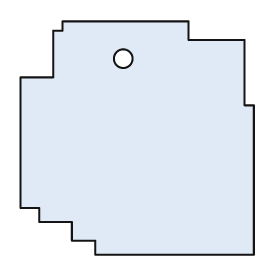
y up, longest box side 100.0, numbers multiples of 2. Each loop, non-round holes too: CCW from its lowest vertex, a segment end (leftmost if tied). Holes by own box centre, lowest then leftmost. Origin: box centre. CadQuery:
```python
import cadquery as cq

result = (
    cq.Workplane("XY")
    .moveTo(-18.0, -50.0)
    .lineTo(50.0, -50.0)
    .lineTo(50.0, 14.0)
    .lineTo(46.0, 14.0)
    .lineTo(46.0, 42.0)
    .lineTo(22.0, 42.0)
    .lineTo(22.0, 50.0)
    .lineTo(-32.0, 50.0)
    .lineTo(-32.0, 46.0)
    .lineTo(-36.0, 46.0)
    .lineTo(-36.0, 26.0)
    .lineTo(-50.0, 26.0)
    .lineTo(-50.0, -30.0)
    .lineTo(-42.0, -30.0)
    .lineTo(-42.0, -36.0)
    .lineTo(-28.0, -36.0)
    .lineTo(-28.0, -44.0)
    .lineTo(-18.0, -44.0)
    .close()
    .moveTo(-6.0, 34.0)
    .circle(4.0)
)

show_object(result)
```